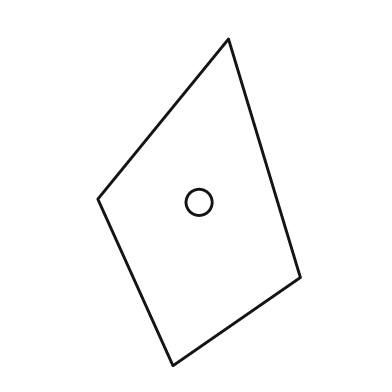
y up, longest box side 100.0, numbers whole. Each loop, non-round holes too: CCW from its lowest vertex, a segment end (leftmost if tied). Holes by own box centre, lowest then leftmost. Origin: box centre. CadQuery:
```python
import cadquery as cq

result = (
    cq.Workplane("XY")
    .moveTo(-8.0, -50.0)
    .lineTo(31.0, -23.0)
    .lineTo(9.0, 50.0)
    .lineTo(-31.0, 1.0)
    .close()
    .moveTo(0.0, 0.0)
    .circle(4.0)
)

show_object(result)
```